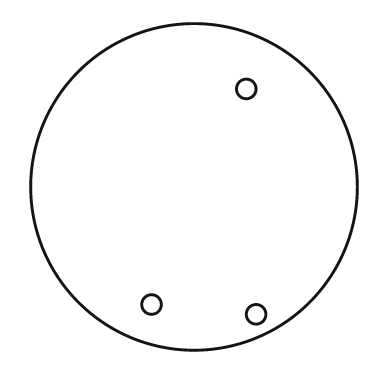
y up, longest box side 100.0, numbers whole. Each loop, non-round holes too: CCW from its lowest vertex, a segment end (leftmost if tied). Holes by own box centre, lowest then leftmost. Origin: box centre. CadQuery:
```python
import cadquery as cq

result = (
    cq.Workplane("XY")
    .moveTo(0.0, 0.0)
    .circle(50.0)
    .moveTo(19.0, -39.0)
    .circle(3.0)
    .moveTo(-13.0, -36.0)
    .circle(3.0)
    .moveTo(16.0, 30.0)
    .circle(3.0)
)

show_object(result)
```